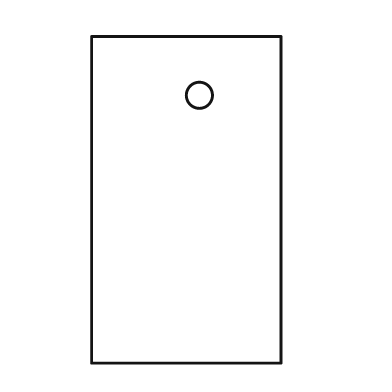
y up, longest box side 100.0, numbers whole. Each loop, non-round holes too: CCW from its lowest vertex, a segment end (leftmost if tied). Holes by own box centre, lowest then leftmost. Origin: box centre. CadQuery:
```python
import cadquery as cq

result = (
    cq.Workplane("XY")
    .moveTo(-29.0, -50.0)
    .lineTo(29.0, -50.0)
    .lineTo(29.0, 50.0)
    .lineTo(-29.0, 50.0)
    .close()
    .moveTo(4.0, 32.0)
    .circle(4.0)
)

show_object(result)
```